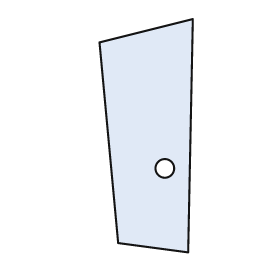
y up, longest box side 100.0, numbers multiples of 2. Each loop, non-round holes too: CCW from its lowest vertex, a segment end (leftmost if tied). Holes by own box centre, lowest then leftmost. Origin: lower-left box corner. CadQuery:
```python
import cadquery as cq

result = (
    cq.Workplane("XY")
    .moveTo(38.0, 0.0)
    .lineTo(40.0, 100.0)
    .lineTo(0.0, 90.0)
    .lineTo(8.0, 4.0)
    .close()
    .moveTo(28.0, 36.0)
    .circle(4.0)
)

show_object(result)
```